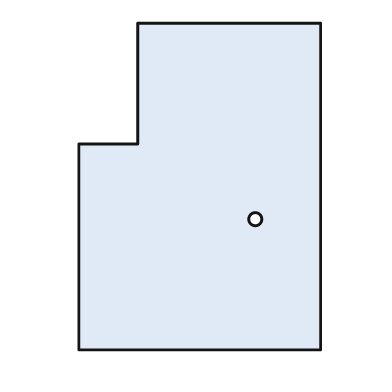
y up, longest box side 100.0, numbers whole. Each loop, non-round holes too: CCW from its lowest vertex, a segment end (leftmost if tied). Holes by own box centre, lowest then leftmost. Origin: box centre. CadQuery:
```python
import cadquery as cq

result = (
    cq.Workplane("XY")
    .moveTo(-37.0, -50.0)
    .lineTo(37.0, -50.0)
    .lineTo(37.0, 50.0)
    .lineTo(-19.0, 50.0)
    .lineTo(-19.0, 13.0)
    .lineTo(-37.0, 13.0)
    .close()
    .moveTo(17.0, -10.0)
    .circle(2.0)
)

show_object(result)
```